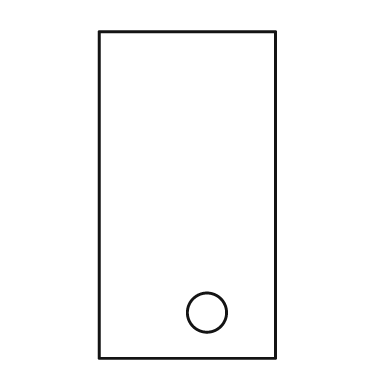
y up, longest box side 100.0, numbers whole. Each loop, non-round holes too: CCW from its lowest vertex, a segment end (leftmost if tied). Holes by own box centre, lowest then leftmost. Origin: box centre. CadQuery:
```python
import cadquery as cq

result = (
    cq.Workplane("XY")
    .moveTo(-27.0, -50.0)
    .lineTo(27.0, -50.0)
    .lineTo(27.0, 50.0)
    .lineTo(-27.0, 50.0)
    .close()
    .moveTo(6.0, -36.0)
    .circle(6.0)
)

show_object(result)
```